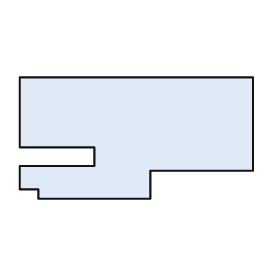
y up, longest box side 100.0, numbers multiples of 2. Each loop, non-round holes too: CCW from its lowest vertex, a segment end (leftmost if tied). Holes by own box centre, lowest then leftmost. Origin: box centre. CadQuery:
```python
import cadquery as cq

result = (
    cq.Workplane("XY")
    .moveTo(-42.0, -26.0)
    .lineTo(6.0, -26.0)
    .lineTo(6.0, -14.0)
    .lineTo(50.0, -14.0)
    .lineTo(50.0, 26.0)
    .lineTo(-50.0, 26.0)
    .lineTo(-50.0, -4.0)
    .lineTo(-18.0, -4.0)
    .lineTo(-18.0, -12.0)
    .lineTo(-50.0, -12.0)
    .lineTo(-50.0, -22.0)
    .lineTo(-42.0, -22.0)
    .close()
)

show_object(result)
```